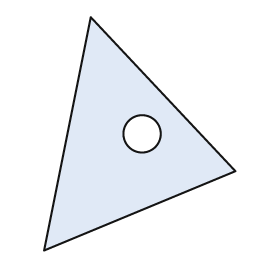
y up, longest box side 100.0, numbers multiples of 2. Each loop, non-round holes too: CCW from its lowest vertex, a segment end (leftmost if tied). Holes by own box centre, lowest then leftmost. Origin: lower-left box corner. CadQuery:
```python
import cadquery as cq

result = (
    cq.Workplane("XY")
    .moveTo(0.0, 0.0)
    .lineTo(82.0, 34.0)
    .lineTo(20.0, 100.0)
    .close()
    .moveTo(42.0, 50.0)
    .circle(8.0)
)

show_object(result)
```